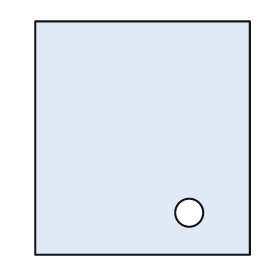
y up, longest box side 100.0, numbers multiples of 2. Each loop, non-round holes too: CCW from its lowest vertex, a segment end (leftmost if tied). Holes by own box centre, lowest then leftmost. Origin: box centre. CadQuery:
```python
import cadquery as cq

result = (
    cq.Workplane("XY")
    .moveTo(-46.0, -50.0)
    .lineTo(46.0, -50.0)
    .lineTo(46.0, 50.0)
    .lineTo(-46.0, 50.0)
    .close()
    .moveTo(20.0, -32.0)
    .circle(6.0)
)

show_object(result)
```